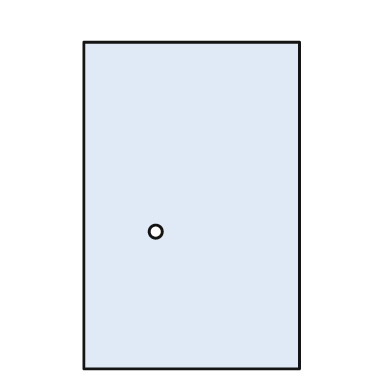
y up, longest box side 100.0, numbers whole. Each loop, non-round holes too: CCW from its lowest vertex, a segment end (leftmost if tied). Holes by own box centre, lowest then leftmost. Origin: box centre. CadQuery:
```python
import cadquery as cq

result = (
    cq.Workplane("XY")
    .moveTo(-33.0, -50.0)
    .lineTo(33.0, -50.0)
    .lineTo(33.0, 50.0)
    .lineTo(-33.0, 50.0)
    .close()
    .moveTo(-11.0, -8.0)
    .circle(2.0)
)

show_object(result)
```